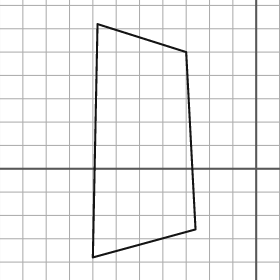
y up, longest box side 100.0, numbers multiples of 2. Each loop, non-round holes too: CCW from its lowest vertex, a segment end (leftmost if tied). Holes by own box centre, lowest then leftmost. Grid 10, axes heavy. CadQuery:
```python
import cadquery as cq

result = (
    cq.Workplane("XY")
    .moveTo(-70.0, -38.0)
    .lineTo(-26.0, -26.0)
    .lineTo(-30.0, 50.0)
    .lineTo(-68.0, 62.0)
    .close()
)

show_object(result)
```